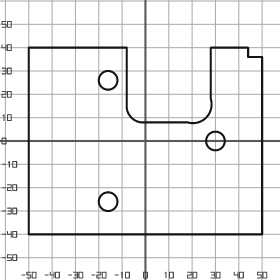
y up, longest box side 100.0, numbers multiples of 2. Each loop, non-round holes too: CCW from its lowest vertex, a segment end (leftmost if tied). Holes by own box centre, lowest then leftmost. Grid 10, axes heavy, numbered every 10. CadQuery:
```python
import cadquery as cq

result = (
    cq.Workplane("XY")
    .moveTo(-50.0, -40.0)
    .lineTo(50.0, -40.0)
    .lineTo(50.0, 36.0)
    .lineTo(44.0, 36.0)
    .lineTo(44.0, 40.0)
    .lineTo(28.0, 40.0)
    .lineTo(28.0, 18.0)
    .threePointArc((26.0, 10.0), (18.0, 8.0))
    .lineTo(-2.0, 8.0)
    .threePointArc((-6.0, 10.0), (-8.0, 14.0))
    .lineTo(-8.0, 40.0)
    .lineTo(-50.0, 40.0)
    .close()
    .moveTo(-16.0, -26.0)
    .circle(4.0)
    .moveTo(30.0, 0.0)
    .circle(4.0)
    .moveTo(-16.0, 26.0)
    .circle(4.0)
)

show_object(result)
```